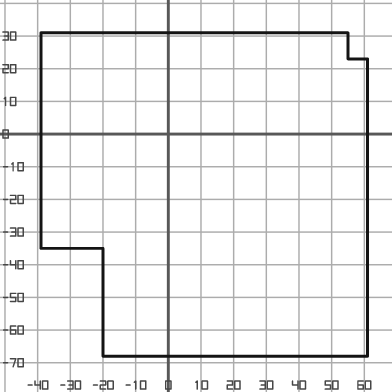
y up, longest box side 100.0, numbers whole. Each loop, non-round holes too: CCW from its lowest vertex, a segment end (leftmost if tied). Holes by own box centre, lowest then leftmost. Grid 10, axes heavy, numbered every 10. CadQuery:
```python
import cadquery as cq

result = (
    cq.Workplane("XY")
    .moveTo(-20.0, -68.0)
    .lineTo(61.0, -68.0)
    .lineTo(61.0, 23.0)
    .lineTo(55.0, 23.0)
    .lineTo(55.0, 31.0)
    .lineTo(-39.0, 31.0)
    .lineTo(-39.0, -35.0)
    .lineTo(-20.0, -35.0)
    .close()
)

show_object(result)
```